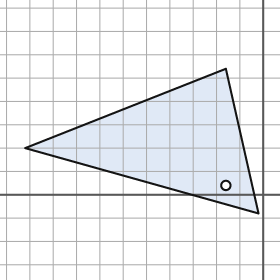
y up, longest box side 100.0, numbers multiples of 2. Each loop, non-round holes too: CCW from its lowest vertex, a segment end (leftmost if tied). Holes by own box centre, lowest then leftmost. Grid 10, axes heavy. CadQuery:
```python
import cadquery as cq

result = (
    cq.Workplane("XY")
    .moveTo(-2.0, -8.0)
    .lineTo(-16.0, 54.0)
    .lineTo(-102.0, 20.0)
    .close()
    .moveTo(-16.0, 4.0)
    .circle(2.0)
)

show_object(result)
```